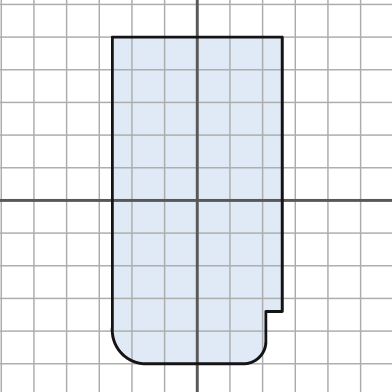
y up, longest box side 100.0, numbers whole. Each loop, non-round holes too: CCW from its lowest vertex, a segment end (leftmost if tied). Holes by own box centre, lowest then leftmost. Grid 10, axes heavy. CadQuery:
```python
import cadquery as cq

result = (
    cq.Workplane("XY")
    .moveTo(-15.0, -50.0)
    .lineTo(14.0, -50.0)
    .threePointArc((19.0, -48.0), (21.0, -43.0))
    .lineTo(21.0, -34.0)
    .lineTo(26.0, -34.0)
    .lineTo(26.0, 50.0)
    .lineTo(-26.0, 50.0)
    .lineTo(-26.0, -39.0)
    .threePointArc((-23.0, -47.0), (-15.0, -50.0))
    .close()
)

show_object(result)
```